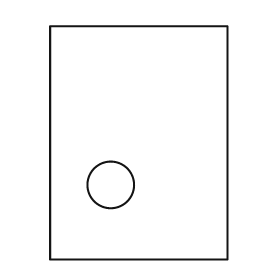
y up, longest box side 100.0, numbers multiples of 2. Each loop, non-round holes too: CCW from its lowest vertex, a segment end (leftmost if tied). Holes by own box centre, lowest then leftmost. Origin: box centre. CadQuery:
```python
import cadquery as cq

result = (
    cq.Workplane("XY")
    .moveTo(-38.0, -50.0)
    .lineTo(38.0, -50.0)
    .lineTo(38.0, 50.0)
    .lineTo(-38.0, 50.0)
    .close()
    .moveTo(-12.0, -18.0)
    .circle(10.0)
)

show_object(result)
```